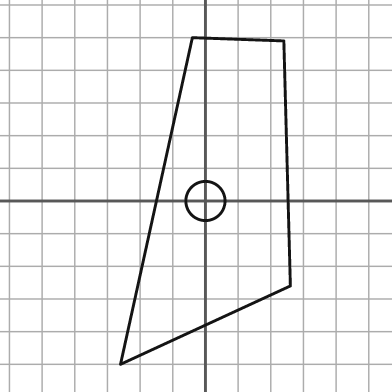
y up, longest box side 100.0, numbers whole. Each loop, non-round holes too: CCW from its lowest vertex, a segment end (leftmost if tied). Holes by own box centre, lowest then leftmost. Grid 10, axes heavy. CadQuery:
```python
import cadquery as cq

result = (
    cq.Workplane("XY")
    .moveTo(-26.0, -50.0)
    .lineTo(26.0, -26.0)
    .lineTo(24.0, 49.0)
    .lineTo(-4.0, 50.0)
    .close()
    .moveTo(0.0, 0.0)
    .circle(6.0)
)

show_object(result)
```